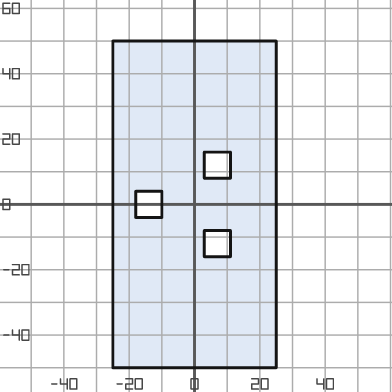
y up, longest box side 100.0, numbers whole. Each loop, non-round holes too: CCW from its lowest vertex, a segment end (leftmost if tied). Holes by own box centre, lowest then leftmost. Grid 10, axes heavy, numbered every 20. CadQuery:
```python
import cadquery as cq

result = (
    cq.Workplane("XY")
    .moveTo(-25.0, -50.0)
    .lineTo(25.0, -50.0)
    .lineTo(25.0, 50.0)
    .lineTo(-25.0, 50.0)
    .close()
    .moveTo(3.0, -16.0)
    .lineTo(11.0, -16.0)
    .lineTo(11.0, -8.0)
    .lineTo(3.0, -8.0)
    .close()
    .moveTo(-18.0, -4.0)
    .lineTo(-10.0, -4.0)
    .lineTo(-10.0, 4.0)
    .lineTo(-18.0, 4.0)
    .close()
    .moveTo(3.0, 8.0)
    .lineTo(11.0, 8.0)
    .lineTo(11.0, 16.0)
    .lineTo(3.0, 16.0)
    .close()
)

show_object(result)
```